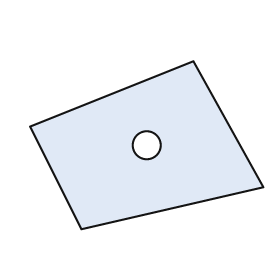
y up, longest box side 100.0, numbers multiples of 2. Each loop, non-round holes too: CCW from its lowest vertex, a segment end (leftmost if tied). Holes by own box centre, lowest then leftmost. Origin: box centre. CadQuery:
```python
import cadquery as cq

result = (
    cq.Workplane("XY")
    .moveTo(-28.0, -36.0)
    .lineTo(50.0, -18.0)
    .lineTo(20.0, 36.0)
    .lineTo(-50.0, 8.0)
    .close()
    .moveTo(0.0, 0.0)
    .circle(6.0)
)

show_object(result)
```